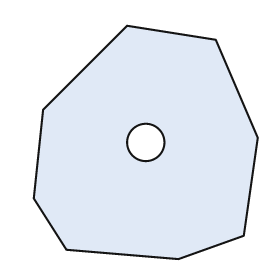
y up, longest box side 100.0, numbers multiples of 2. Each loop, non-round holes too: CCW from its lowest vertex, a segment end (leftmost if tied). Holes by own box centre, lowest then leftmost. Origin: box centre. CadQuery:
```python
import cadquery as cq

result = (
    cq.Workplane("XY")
    .moveTo(14.0, -50.0)
    .lineTo(42.0, -40.0)
    .lineTo(48.0, 2.0)
    .lineTo(30.0, 44.0)
    .lineTo(-8.0, 50.0)
    .lineTo(-44.0, 14.0)
    .lineTo(-48.0, -24.0)
    .lineTo(-34.0, -46.0)
    .close()
    .moveTo(0.0, 0.0)
    .circle(8.0)
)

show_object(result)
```